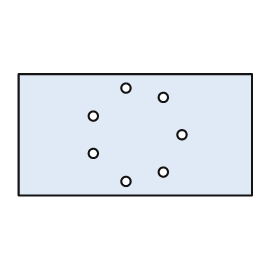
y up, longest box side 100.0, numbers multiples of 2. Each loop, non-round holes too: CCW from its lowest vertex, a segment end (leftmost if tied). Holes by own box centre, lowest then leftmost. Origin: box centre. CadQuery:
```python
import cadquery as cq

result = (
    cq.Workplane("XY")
    .moveTo(-50.0, -26.0)
    .lineTo(50.0, -26.0)
    .lineTo(50.0, 26.0)
    .lineTo(-50.0, 26.0)
    .close()
    .moveTo(-4.0, -20.0)
    .circle(2.0)
    .moveTo(12.0, -16.0)
    .circle(2.0)
    .moveTo(-18.0, -8.0)
    .circle(2.0)
    .moveTo(20.0, 0.0)
    .circle(2.0)
    .moveTo(-18.0, 8.0)
    .circle(2.0)
    .moveTo(12.0, 16.0)
    .circle(2.0)
    .moveTo(-4.0, 20.0)
    .circle(2.0)
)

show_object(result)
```